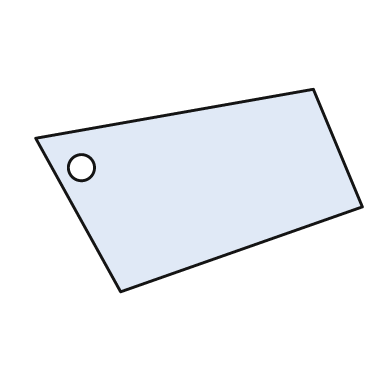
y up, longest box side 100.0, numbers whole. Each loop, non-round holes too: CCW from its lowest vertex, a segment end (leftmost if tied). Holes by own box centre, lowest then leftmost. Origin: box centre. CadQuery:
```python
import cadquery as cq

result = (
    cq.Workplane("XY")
    .moveTo(-24.0, -31.0)
    .lineTo(50.0, -5.0)
    .lineTo(35.0, 31.0)
    .lineTo(-50.0, 16.0)
    .close()
    .moveTo(-36.0, 7.0)
    .circle(4.0)
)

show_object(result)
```